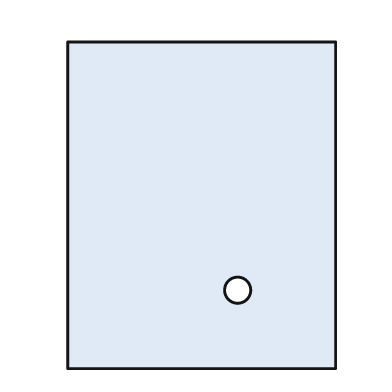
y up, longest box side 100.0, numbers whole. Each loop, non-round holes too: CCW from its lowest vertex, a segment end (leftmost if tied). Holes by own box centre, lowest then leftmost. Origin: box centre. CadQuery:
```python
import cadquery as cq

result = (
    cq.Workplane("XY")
    .moveTo(-41.0, -50.0)
    .lineTo(41.0, -50.0)
    .lineTo(41.0, 50.0)
    .lineTo(-41.0, 50.0)
    .close()
    .moveTo(11.0, -26.0)
    .circle(4.0)
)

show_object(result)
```